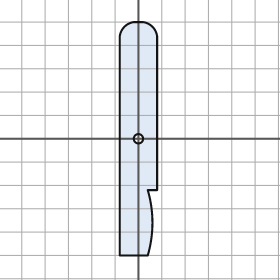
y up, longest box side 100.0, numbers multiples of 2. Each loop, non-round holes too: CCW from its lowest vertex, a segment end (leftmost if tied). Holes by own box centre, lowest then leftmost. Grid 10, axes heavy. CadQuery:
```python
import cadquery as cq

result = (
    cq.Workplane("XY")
    .moveTo(-8.0, -50.0)
    .lineTo(4.0, -50.0)
    .threePointArc((6.0, -36.0), (4.0, -22.0))
    .lineTo(8.0, -22.0)
    .lineTo(8.0, 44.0)
    .threePointArc((6.0, 48.0), (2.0, 50.0))
    .lineTo(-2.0, 50.0)
    .threePointArc((-6.0, 48.0), (-8.0, 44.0))
    .close()
    .moveTo(0.0, 0.0)
    .circle(2.0)
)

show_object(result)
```